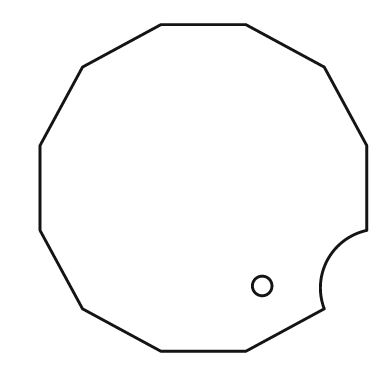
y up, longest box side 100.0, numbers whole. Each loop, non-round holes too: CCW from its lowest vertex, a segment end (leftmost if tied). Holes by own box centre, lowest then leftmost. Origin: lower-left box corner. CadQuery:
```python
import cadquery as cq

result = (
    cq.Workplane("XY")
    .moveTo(37.0, 0.0)
    .lineTo(63.0, 0.0)
    .lineTo(87.0, 13.0)
    .threePointArc((88.0, 28.0), (100.0, 37.0))
    .lineTo(100.0, 63.0)
    .lineTo(87.0, 87.0)
    .lineTo(63.0, 100.0)
    .lineTo(37.0, 100.0)
    .lineTo(13.0, 87.0)
    .lineTo(0.0, 63.0)
    .lineTo(0.0, 37.0)
    .lineTo(13.0, 13.0)
    .close()
    .moveTo(68.0, 20.0)
    .circle(3.0)
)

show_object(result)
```